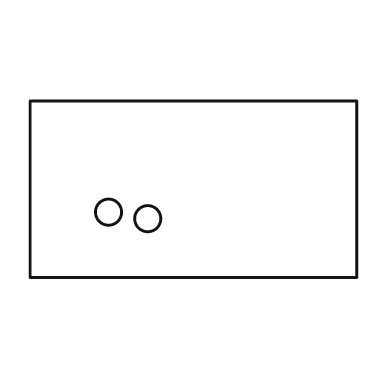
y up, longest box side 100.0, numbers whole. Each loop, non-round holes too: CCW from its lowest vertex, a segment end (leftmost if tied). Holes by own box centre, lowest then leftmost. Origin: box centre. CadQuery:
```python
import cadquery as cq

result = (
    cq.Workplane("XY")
    .moveTo(-50.0, -27.0)
    .lineTo(50.0, -27.0)
    .lineTo(50.0, 27.0)
    .lineTo(-50.0, 27.0)
    .close()
    .moveTo(-14.0, -9.0)
    .circle(4.0)
    .moveTo(-26.0, -7.0)
    .circle(4.0)
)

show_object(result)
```